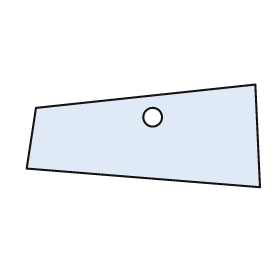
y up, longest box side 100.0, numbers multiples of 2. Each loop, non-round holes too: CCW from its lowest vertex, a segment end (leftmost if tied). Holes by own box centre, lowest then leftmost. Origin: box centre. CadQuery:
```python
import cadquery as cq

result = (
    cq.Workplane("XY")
    .moveTo(50.0, -22.0)
    .lineTo(48.0, 22.0)
    .lineTo(-46.0, 12.0)
    .lineTo(-50.0, -14.0)
    .close()
    .moveTo(4.0, 8.0)
    .circle(4.0)
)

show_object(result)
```